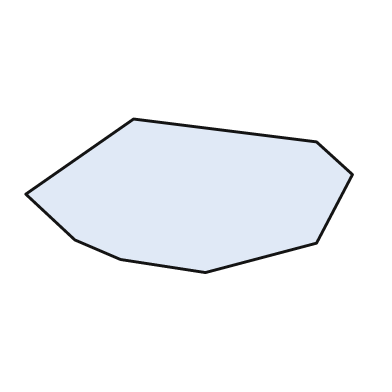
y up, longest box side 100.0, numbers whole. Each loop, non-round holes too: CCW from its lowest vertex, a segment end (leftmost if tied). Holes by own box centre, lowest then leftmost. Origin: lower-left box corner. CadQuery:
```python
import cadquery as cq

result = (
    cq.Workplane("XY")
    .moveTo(55.0, 0.0)
    .lineTo(89.0, 9.0)
    .lineTo(100.0, 30.0)
    .lineTo(89.0, 40.0)
    .lineTo(33.0, 47.0)
    .lineTo(0.0, 24.0)
    .lineTo(15.0, 10.0)
    .lineTo(29.0, 4.0)
    .close()
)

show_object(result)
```